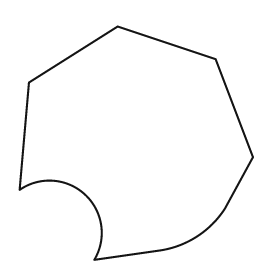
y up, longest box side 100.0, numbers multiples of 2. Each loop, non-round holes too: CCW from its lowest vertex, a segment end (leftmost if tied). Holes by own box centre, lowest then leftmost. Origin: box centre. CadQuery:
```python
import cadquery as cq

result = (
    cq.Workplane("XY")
    .moveTo(-18.0, -50.0)
    .lineTo(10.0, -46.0)
    .threePointArc((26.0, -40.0), (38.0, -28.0))
    .lineTo(50.0, -6.0)
    .lineTo(34.0, 36.0)
    .lineTo(-8.0, 50.0)
    .lineTo(-46.0, 26.0)
    .lineTo(-50.0, -20.0)
    .threePointArc((-22.0, -22.0), (-18.0, -50.0))
    .close()
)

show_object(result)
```